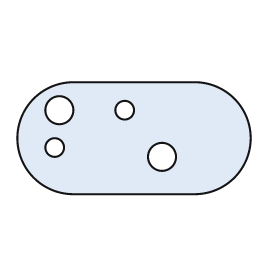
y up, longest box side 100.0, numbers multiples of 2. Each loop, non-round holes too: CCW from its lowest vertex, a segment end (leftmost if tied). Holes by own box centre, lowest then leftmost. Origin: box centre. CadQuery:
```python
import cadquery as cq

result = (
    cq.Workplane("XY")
    .moveTo(-26.0, -24.0)
    .lineTo(26.0, -24.0)
    .threePointArc((50.0, 0.0), (26.0, 24.0))
    .lineTo(-26.0, 24.0)
    .threePointArc((-50.0, 0.0), (-26.0, -24.0))
    .close()
    .moveTo(12.0, -8.0)
    .circle(6.0)
    .moveTo(-34.0, -4.0)
    .circle(4.0)
    .moveTo(-32.0, 12.0)
    .circle(6.0)
    .moveTo(-4.0, 12.0)
    .circle(4.0)
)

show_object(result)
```